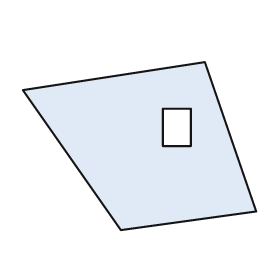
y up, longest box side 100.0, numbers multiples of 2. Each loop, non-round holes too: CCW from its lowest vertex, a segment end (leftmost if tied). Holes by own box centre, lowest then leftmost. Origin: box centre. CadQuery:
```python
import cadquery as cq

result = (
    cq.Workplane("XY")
    .moveTo(-8.0, -36.0)
    .lineTo(50.0, -28.0)
    .lineTo(28.0, 36.0)
    .lineTo(-50.0, 24.0)
    .close()
    .moveTo(10.0, 0.0)
    .lineTo(22.0, 0.0)
    .lineTo(22.0, 16.0)
    .lineTo(10.0, 16.0)
    .close()
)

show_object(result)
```